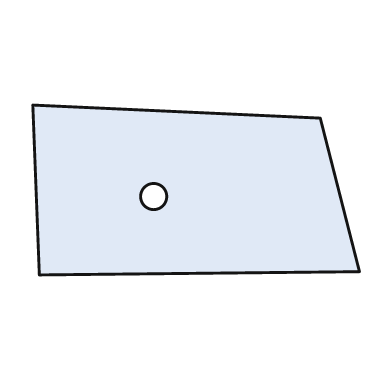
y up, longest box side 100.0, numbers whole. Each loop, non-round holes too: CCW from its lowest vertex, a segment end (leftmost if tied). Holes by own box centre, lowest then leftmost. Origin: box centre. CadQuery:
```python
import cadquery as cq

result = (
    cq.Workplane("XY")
    .moveTo(-48.0, -26.0)
    .lineTo(50.0, -25.0)
    .lineTo(38.0, 22.0)
    .lineTo(-50.0, 26.0)
    .close()
    .moveTo(-13.0, -2.0)
    .circle(4.0)
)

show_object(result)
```